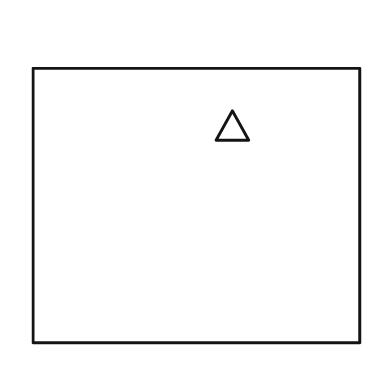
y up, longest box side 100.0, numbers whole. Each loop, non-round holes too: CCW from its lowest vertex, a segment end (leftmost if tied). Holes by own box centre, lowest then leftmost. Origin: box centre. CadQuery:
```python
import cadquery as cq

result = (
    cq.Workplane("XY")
    .moveTo(-50.0, -42.0)
    .lineTo(50.0, -42.0)
    .lineTo(50.0, 42.0)
    .lineTo(-50.0, 42.0)
    .close()
    .moveTo(6.0, 20.0)
    .lineTo(16.0, 20.0)
    .lineTo(11.0, 29.0)
    .close()
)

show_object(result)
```